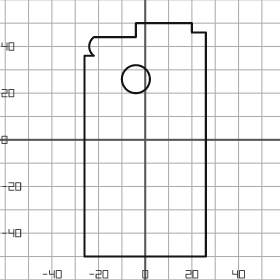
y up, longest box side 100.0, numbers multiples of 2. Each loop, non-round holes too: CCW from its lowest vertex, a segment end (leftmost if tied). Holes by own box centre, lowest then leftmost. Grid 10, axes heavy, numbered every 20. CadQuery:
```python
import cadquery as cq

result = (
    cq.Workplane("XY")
    .moveTo(-26.0, -50.0)
    .lineTo(26.0, -50.0)
    .lineTo(26.0, 46.0)
    .lineTo(20.0, 46.0)
    .lineTo(20.0, 50.0)
    .lineTo(-4.0, 50.0)
    .lineTo(-4.0, 44.0)
    .lineTo(-22.0, 44.0)
    .threePointArc((-24.0, 40.0), (-22.0, 36.0))
    .lineTo(-26.0, 36.0)
    .close()
    .moveTo(-4.0, 26.0)
    .circle(6.0)
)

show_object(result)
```